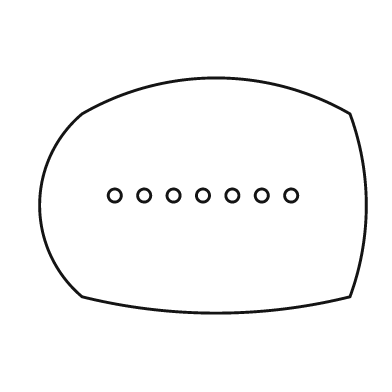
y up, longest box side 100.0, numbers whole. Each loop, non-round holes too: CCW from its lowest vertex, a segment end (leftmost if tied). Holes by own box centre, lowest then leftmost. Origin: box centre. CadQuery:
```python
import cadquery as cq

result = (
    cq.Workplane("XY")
    .moveTo(-37.0, -31.0)
    .threePointArc((4.0, -36.0), (45.0, -31.0))
    .threePointArc((50.0, -3.0), (45.0, 25.0))
    .threePointArc((4.0, 36.0), (-37.0, 25.0))
    .threePointArc((-50.0, -3.0), (-37.0, -31.0))
    .close()
    .moveTo(-27.0, 0.0)
    .circle(2.0)
    .moveTo(-18.0, 0.0)
    .circle(2.0)
    .moveTo(-9.0, 0.0)
    .circle(2.0)
    .moveTo(0.0, 0.0)
    .circle(2.0)
    .moveTo(9.0, 0.0)
    .circle(2.0)
    .moveTo(18.0, 0.0)
    .circle(2.0)
    .moveTo(27.0, 0.0)
    .circle(2.0)
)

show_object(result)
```